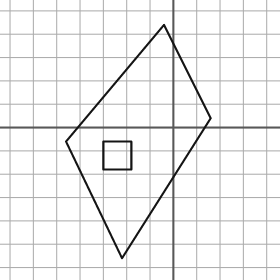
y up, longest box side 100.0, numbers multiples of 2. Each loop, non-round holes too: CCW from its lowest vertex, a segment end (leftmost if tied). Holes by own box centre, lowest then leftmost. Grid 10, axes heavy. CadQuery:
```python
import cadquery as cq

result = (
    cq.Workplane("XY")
    .moveTo(-22.0, -56.0)
    .lineTo(16.0, 4.0)
    .lineTo(-4.0, 44.0)
    .lineTo(-46.0, -6.0)
    .close()
    .moveTo(-30.0, -18.0)
    .lineTo(-18.0, -18.0)
    .lineTo(-18.0, -6.0)
    .lineTo(-30.0, -6.0)
    .close()
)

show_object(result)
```